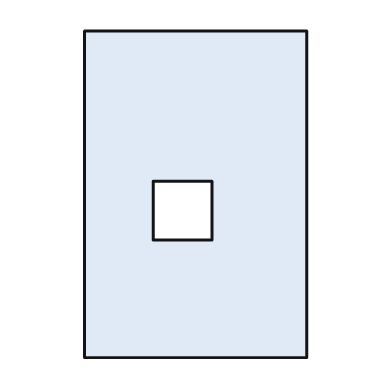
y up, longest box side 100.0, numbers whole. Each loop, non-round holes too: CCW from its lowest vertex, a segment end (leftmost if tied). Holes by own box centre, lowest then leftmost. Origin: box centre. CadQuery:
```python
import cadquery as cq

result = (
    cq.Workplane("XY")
    .moveTo(-34.0, -50.0)
    .lineTo(34.0, -50.0)
    .lineTo(34.0, 50.0)
    .lineTo(-34.0, 50.0)
    .close()
    .moveTo(-13.0, -14.0)
    .lineTo(5.0, -14.0)
    .lineTo(5.0, 4.0)
    .lineTo(-13.0, 4.0)
    .close()
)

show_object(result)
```